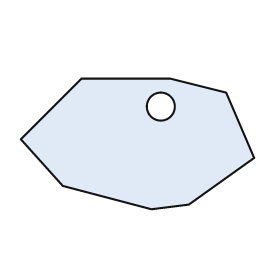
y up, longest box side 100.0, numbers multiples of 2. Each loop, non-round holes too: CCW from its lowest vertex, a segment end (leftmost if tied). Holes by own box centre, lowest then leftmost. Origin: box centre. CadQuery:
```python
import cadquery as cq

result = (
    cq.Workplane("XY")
    .moveTo(6.0, -28.0)
    .lineTo(22.0, -26.0)
    .lineTo(50.0, -6.0)
    .lineTo(38.0, 22.0)
    .lineTo(14.0, 28.0)
    .lineTo(-24.0, 28.0)
    .lineTo(-50.0, 2.0)
    .lineTo(-32.0, -18.0)
    .close()
    .moveTo(10.0, 16.0)
    .circle(6.0)
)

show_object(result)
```